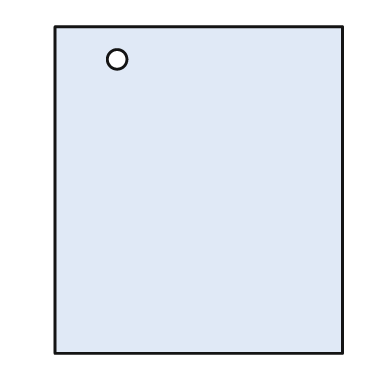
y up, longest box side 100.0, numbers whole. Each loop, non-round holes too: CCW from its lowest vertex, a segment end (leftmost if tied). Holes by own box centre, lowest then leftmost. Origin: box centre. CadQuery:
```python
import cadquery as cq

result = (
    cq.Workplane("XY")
    .moveTo(-44.0, -50.0)
    .lineTo(44.0, -50.0)
    .lineTo(44.0, 50.0)
    .lineTo(-44.0, 50.0)
    .close()
    .moveTo(-25.0, 40.0)
    .circle(3.0)
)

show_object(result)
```